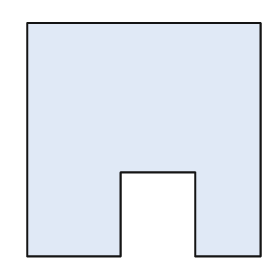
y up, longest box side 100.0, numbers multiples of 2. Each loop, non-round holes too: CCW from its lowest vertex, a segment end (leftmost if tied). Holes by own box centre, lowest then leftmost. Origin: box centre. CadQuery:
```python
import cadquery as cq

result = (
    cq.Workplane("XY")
    .moveTo(-50.0, -50.0)
    .lineTo(-10.0, -50.0)
    .lineTo(-10.0, -14.0)
    .lineTo(22.0, -14.0)
    .lineTo(22.0, -50.0)
    .lineTo(50.0, -50.0)
    .lineTo(50.0, 50.0)
    .lineTo(-50.0, 50.0)
    .close()
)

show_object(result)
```